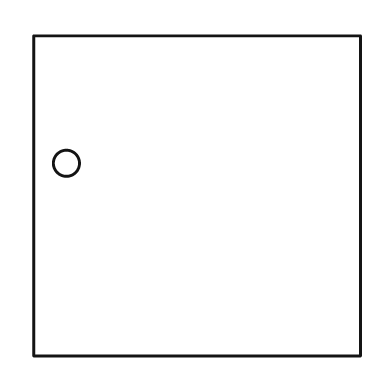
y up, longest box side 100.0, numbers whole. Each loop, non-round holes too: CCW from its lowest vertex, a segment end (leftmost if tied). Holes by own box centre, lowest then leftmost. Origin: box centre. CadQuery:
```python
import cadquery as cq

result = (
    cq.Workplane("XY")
    .moveTo(-50.0, -49.0)
    .lineTo(50.0, -49.0)
    .lineTo(50.0, 49.0)
    .lineTo(-50.0, 49.0)
    .close()
    .moveTo(-40.0, 10.0)
    .circle(4.0)
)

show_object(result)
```